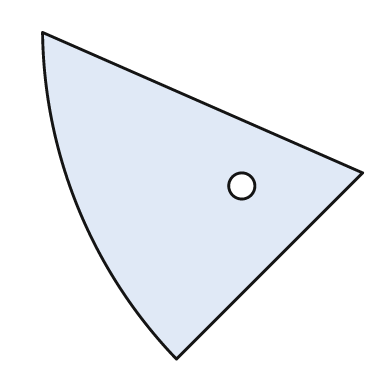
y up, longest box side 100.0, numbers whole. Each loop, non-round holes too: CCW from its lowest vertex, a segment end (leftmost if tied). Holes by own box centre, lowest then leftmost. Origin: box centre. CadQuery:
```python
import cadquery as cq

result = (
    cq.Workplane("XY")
    .moveTo(-8.0, -50.0)
    .lineTo(49.0, 7.0)
    .lineTo(-49.0, 50.0)
    .threePointArc((-38.0, -4.0), (-8.0, -50.0))
    .close()
    .moveTo(12.0, 3.0)
    .circle(4.0)
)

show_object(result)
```